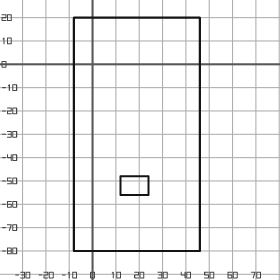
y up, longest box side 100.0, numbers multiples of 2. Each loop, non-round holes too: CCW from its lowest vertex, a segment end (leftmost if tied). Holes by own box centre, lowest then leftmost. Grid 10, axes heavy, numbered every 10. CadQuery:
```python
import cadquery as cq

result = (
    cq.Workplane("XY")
    .moveTo(-8.0, -80.0)
    .lineTo(46.0, -80.0)
    .lineTo(46.0, 20.0)
    .lineTo(-8.0, 20.0)
    .close()
    .moveTo(12.0, -56.0)
    .lineTo(24.0, -56.0)
    .lineTo(24.0, -48.0)
    .lineTo(12.0, -48.0)
    .close()
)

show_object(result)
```